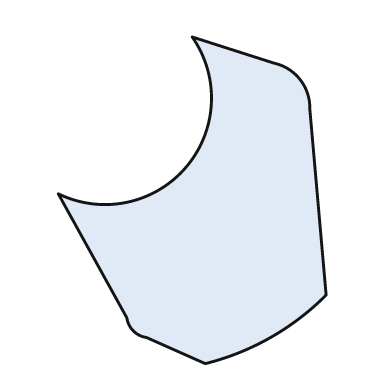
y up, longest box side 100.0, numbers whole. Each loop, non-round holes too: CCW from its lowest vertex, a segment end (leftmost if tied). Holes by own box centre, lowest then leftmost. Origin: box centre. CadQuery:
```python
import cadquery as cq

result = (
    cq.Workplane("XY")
    .moveTo(4.0, -50.0)
    .threePointArc((24.0, -42.0), (41.0, -29.0))
    .lineTo(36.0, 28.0)
    .threePointArc((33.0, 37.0), (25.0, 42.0))
    .lineTo(0.0, 50.0)
    .threePointArc((-2.0, 10.0), (-41.0, 2.0))
    .lineTo(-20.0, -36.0)
    .threePointArc((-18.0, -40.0), (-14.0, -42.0))
    .close()
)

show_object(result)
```